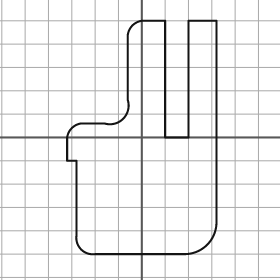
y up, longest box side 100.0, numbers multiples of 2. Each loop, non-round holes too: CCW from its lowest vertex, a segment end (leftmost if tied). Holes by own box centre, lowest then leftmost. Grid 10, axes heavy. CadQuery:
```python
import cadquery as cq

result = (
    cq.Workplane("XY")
    .moveTo(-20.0, -50.0)
    .lineTo(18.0, -50.0)
    .threePointArc((28.0, -46.0), (32.0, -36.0))
    .lineTo(32.0, 50.0)
    .lineTo(20.0, 50.0)
    .lineTo(20.0, 0.0)
    .lineTo(10.0, 0.0)
    .lineTo(10.0, 50.0)
    .lineTo(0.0, 50.0)
    .threePointArc((-4.0, 48.0), (-6.0, 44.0))
    .lineTo(-6.0, 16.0)
    .threePointArc((-8.0, 8.0), (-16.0, 6.0))
    .lineTo(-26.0, 6.0)
    .threePointArc((-30.0, 4.0), (-32.0, 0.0))
    .lineTo(-32.0, -10.0)
    .lineTo(-28.0, -10.0)
    .lineTo(-28.0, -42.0)
    .threePointArc((-26.0, -48.0), (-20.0, -50.0))
    .close()
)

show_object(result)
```